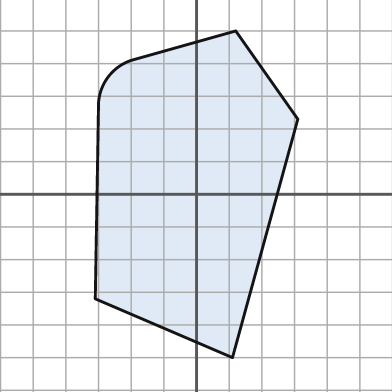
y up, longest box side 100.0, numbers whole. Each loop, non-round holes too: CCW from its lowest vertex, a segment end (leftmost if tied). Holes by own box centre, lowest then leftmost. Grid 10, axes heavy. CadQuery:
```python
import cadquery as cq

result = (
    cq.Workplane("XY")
    .moveTo(11.0, -50.0)
    .lineTo(31.0, 23.0)
    .lineTo(12.0, 50.0)
    .lineTo(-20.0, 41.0)
    .threePointArc((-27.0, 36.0), (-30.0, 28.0))
    .lineTo(-31.0, -32.0)
    .close()
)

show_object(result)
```